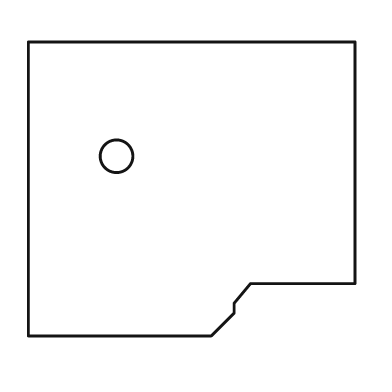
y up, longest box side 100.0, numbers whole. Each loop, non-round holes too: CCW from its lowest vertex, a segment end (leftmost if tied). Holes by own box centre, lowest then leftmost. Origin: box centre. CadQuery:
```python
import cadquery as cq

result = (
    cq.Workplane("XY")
    .moveTo(-50.0, -45.0)
    .lineTo(6.0, -45.0)
    .lineTo(13.0, -38.0)
    .lineTo(13.0, -35.0)
    .lineTo(18.0, -29.0)
    .lineTo(50.0, -29.0)
    .lineTo(50.0, 45.0)
    .lineTo(-50.0, 45.0)
    .close()
    .moveTo(-23.0, 10.0)
    .circle(5.0)
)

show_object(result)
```